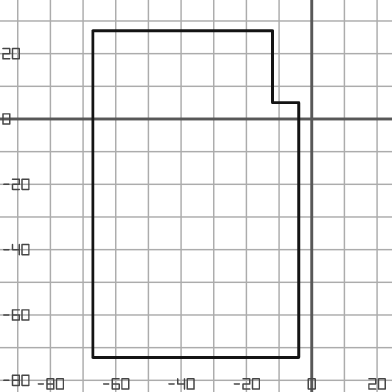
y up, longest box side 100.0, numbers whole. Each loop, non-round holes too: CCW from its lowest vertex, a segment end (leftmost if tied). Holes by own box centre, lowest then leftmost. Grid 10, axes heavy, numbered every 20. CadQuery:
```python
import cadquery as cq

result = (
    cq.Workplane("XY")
    .moveTo(-67.0, -73.0)
    .lineTo(-4.0, -73.0)
    .lineTo(-4.0, 5.0)
    .lineTo(-12.0, 5.0)
    .lineTo(-12.0, 27.0)
    .lineTo(-67.0, 27.0)
    .close()
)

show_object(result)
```